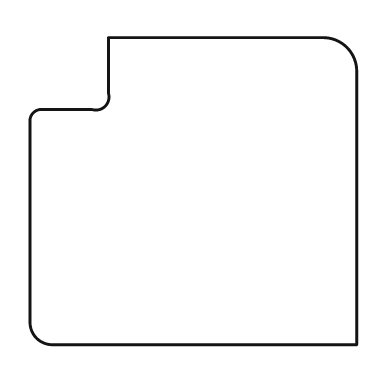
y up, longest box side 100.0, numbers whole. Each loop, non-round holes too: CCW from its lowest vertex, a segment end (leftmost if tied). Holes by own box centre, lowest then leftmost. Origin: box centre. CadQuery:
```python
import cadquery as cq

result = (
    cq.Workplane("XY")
    .moveTo(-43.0, -47.0)
    .lineTo(50.0, -47.0)
    .lineTo(50.0, 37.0)
    .threePointArc((47.0, 44.0), (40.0, 47.0))
    .lineTo(-26.0, 47.0)
    .lineTo(-26.0, 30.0)
    .threePointArc((-27.0, 26.0), (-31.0, 25.0))
    .lineTo(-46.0, 25.0)
    .threePointArc((-49.0, 24.0), (-50.0, 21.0))
    .lineTo(-50.0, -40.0)
    .threePointArc((-48.0, -45.0), (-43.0, -47.0))
    .close()
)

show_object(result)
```